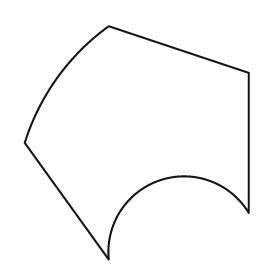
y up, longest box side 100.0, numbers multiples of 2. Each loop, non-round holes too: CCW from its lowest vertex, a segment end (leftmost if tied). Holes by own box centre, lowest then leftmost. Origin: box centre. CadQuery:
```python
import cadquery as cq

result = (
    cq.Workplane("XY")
    .moveTo(-12.0, -50.0)
    .threePointArc((10.0, -16.0), (48.0, -30.0))
    .lineTo(48.0, 30.0)
    .lineTo(-12.0, 50.0)
    .threePointArc((-34.0, 28.0), (-48.0, 0.0))
    .close()
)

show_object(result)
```